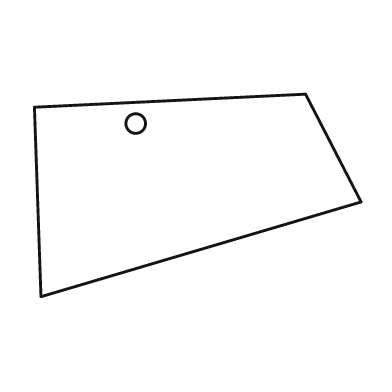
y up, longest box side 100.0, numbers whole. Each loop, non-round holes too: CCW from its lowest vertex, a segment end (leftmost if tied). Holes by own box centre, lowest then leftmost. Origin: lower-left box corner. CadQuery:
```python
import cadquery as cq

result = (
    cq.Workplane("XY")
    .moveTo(2.0, 0.0)
    .lineTo(100.0, 29.0)
    .lineTo(83.0, 62.0)
    .lineTo(0.0, 58.0)
    .close()
    .moveTo(31.0, 53.0)
    .circle(3.0)
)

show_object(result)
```